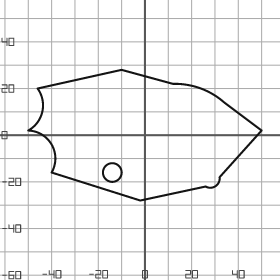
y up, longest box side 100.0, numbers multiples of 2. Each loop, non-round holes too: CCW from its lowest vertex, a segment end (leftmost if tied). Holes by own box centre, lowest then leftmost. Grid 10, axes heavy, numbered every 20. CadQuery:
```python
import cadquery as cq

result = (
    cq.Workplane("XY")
    .moveTo(-2.0, -28.0)
    .lineTo(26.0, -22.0)
    .threePointArc((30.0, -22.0), (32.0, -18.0))
    .lineTo(50.0, 2.0)
    .lineTo(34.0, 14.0)
    .threePointArc((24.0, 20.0), (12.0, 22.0))
    .lineTo(-10.0, 28.0)
    .lineTo(-46.0, 20.0)
    .threePointArc((-44.0, 10.0), (-50.0, 2.0))
    .threePointArc((-40.0, -4.0), (-40.0, -16.0))
    .close()
    .moveTo(-14.0, -16.0)
    .circle(4.0)
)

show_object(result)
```